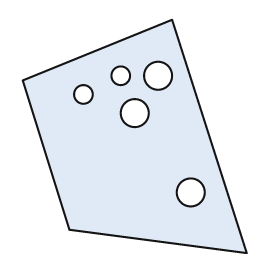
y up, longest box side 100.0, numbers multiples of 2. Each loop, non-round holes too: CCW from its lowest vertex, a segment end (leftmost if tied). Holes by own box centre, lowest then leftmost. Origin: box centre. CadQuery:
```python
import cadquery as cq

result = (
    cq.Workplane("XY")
    .moveTo(48.0, -50.0)
    .lineTo(16.0, 50.0)
    .lineTo(-48.0, 24.0)
    .lineTo(-28.0, -40.0)
    .close()
    .moveTo(24.0, -24.0)
    .circle(6.0)
    .moveTo(0.0, 10.0)
    .circle(6.0)
    .moveTo(-22.0, 18.0)
    .circle(4.0)
    .moveTo(-6.0, 26.0)
    .circle(4.0)
    .moveTo(10.0, 26.0)
    .circle(6.0)
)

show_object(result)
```